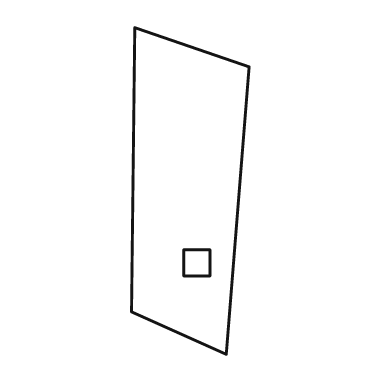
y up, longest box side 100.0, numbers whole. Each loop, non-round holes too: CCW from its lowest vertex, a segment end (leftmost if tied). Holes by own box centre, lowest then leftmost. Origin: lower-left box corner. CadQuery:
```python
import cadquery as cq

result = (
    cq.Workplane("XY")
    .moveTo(29.0, 0.0)
    .lineTo(36.0, 88.0)
    .lineTo(1.0, 100.0)
    .lineTo(0.0, 13.0)
    .close()
    .moveTo(16.0, 24.0)
    .lineTo(24.0, 24.0)
    .lineTo(24.0, 32.0)
    .lineTo(16.0, 32.0)
    .close()
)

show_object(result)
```